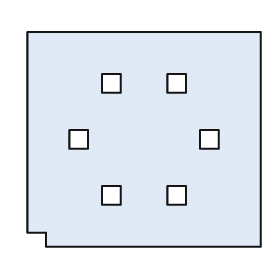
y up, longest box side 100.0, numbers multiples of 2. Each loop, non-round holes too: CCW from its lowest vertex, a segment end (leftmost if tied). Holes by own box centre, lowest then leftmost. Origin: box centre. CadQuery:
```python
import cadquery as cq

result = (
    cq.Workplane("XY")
    .moveTo(-42.0, -46.0)
    .lineTo(50.0, -46.0)
    .lineTo(50.0, 46.0)
    .lineTo(-50.0, 46.0)
    .lineTo(-50.0, -40.0)
    .lineTo(-42.0, -40.0)
    .close()
    .moveTo(-18.0, -28.0)
    .lineTo(-10.0, -28.0)
    .lineTo(-10.0, -20.0)
    .lineTo(-18.0, -20.0)
    .close()
    .moveTo(10.0, -28.0)
    .lineTo(18.0, -28.0)
    .lineTo(18.0, -20.0)
    .lineTo(10.0, -20.0)
    .close()
    .moveTo(-32.0, -4.0)
    .lineTo(-24.0, -4.0)
    .lineTo(-24.0, 4.0)
    .lineTo(-32.0, 4.0)
    .close()
    .moveTo(24.0, -4.0)
    .lineTo(32.0, -4.0)
    .lineTo(32.0, 4.0)
    .lineTo(24.0, 4.0)
    .close()
    .moveTo(-18.0, 20.0)
    .lineTo(-10.0, 20.0)
    .lineTo(-10.0, 28.0)
    .lineTo(-18.0, 28.0)
    .close()
    .moveTo(10.0, 20.0)
    .lineTo(18.0, 20.0)
    .lineTo(18.0, 28.0)
    .lineTo(10.0, 28.0)
    .close()
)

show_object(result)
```